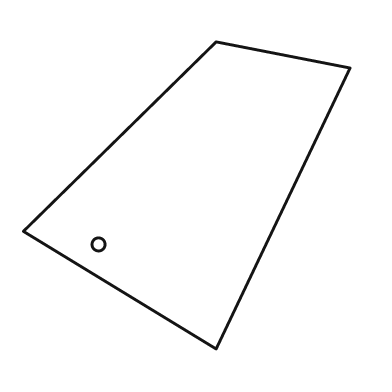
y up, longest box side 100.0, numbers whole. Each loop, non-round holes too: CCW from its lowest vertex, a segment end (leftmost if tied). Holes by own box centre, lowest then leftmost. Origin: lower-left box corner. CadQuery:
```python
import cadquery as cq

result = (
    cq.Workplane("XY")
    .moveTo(59.0, 0.0)
    .lineTo(100.0, 86.0)
    .lineTo(59.0, 94.0)
    .lineTo(0.0, 36.0)
    .close()
    .moveTo(23.0, 32.0)
    .circle(2.0)
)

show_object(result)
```